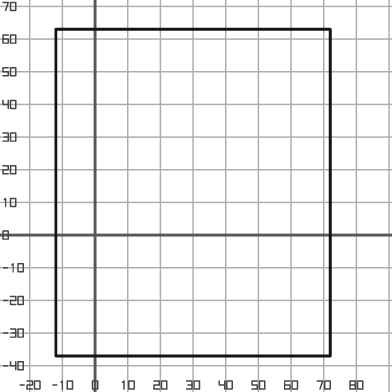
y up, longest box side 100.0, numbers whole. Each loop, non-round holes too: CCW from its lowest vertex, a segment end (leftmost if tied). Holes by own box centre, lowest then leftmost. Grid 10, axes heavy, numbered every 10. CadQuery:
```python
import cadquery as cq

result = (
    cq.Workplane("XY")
    .moveTo(-12.0, -37.0)
    .lineTo(72.0, -37.0)
    .lineTo(72.0, 63.0)
    .lineTo(-12.0, 63.0)
    .close()
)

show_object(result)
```